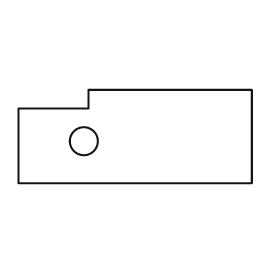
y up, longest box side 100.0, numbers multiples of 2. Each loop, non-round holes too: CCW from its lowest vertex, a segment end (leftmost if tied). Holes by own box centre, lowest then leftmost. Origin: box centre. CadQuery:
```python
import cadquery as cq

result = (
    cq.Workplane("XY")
    .moveTo(-50.0, -20.0)
    .lineTo(50.0, -20.0)
    .lineTo(50.0, 20.0)
    .lineTo(-20.0, 20.0)
    .lineTo(-20.0, 12.0)
    .lineTo(-50.0, 12.0)
    .close()
    .moveTo(-22.0, -2.0)
    .circle(6.0)
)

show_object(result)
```